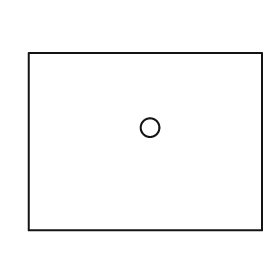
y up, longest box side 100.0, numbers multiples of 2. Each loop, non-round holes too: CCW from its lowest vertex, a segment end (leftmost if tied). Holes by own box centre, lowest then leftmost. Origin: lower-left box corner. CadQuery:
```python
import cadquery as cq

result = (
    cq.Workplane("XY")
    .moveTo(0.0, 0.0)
    .lineTo(100.0, 0.0)
    .lineTo(100.0, 76.0)
    .lineTo(0.0, 76.0)
    .close()
    .moveTo(52.0, 44.0)
    .circle(4.0)
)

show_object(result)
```